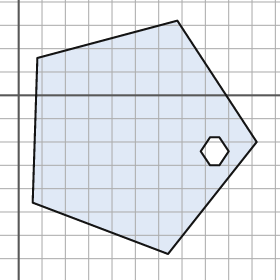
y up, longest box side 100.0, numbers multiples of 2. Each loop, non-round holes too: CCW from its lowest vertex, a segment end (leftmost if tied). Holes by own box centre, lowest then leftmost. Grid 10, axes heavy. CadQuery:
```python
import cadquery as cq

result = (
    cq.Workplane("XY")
    .moveTo(64.0, -68.0)
    .lineTo(102.0, -20.0)
    .lineTo(68.0, 32.0)
    .lineTo(8.0, 16.0)
    .lineTo(6.0, -46.0)
    .close()
    .moveTo(82.0, -30.0)
    .lineTo(86.0, -30.0)
    .lineTo(90.0, -24.0)
    .lineTo(86.0, -18.0)
    .lineTo(82.0, -18.0)
    .lineTo(78.0, -24.0)
    .close()
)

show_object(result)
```